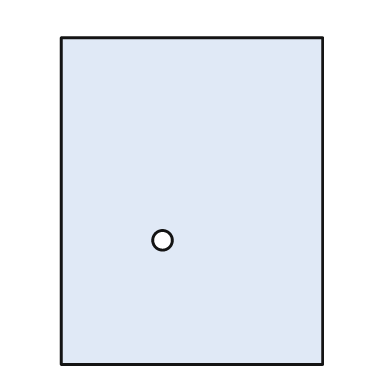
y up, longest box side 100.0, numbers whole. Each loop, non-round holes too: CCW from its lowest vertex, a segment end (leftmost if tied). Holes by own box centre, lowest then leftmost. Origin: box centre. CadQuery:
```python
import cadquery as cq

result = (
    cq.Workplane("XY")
    .moveTo(-40.0, -50.0)
    .lineTo(40.0, -50.0)
    .lineTo(40.0, 50.0)
    .lineTo(-40.0, 50.0)
    .close()
    .moveTo(-9.0, -12.0)
    .circle(3.0)
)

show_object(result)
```